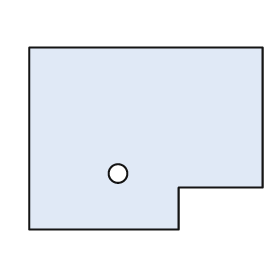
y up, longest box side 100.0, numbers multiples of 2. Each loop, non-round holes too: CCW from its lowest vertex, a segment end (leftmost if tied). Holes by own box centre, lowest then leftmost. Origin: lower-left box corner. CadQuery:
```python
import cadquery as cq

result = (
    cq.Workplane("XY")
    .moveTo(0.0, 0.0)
    .lineTo(64.0, 0.0)
    .lineTo(64.0, 18.0)
    .lineTo(100.0, 18.0)
    .lineTo(100.0, 78.0)
    .lineTo(0.0, 78.0)
    .close()
    .moveTo(38.0, 24.0)
    .circle(4.0)
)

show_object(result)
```